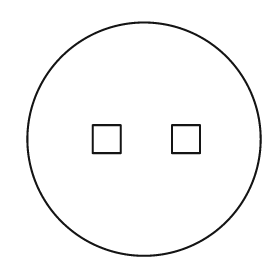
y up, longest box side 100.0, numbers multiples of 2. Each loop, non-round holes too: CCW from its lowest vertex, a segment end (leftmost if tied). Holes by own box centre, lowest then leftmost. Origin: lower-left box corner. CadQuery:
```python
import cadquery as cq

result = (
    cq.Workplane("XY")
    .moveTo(50.0, 50.0)
    .circle(50.0)
    .moveTo(28.0, 44.0)
    .lineTo(40.0, 44.0)
    .lineTo(40.0, 56.0)
    .lineTo(28.0, 56.0)
    .close()
    .moveTo(62.0, 44.0)
    .lineTo(74.0, 44.0)
    .lineTo(74.0, 56.0)
    .lineTo(62.0, 56.0)
    .close()
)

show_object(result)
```